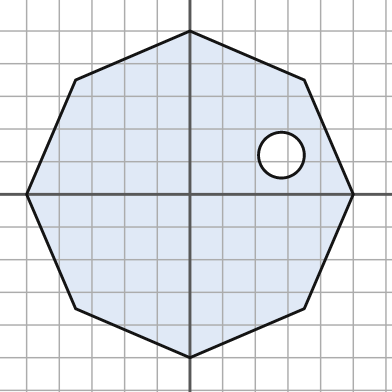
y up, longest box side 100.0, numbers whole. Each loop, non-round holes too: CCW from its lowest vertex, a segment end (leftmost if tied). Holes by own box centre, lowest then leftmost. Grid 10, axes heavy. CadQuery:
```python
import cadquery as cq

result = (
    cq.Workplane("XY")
    .moveTo(0.0, -50.0)
    .lineTo(35.0, -35.0)
    .lineTo(50.0, 0.0)
    .lineTo(35.0, 35.0)
    .lineTo(0.0, 50.0)
    .lineTo(-35.0, 35.0)
    .lineTo(-50.0, 0.0)
    .lineTo(-35.0, -35.0)
    .close()
    .moveTo(28.0, 12.0)
    .circle(7.0)
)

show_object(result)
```